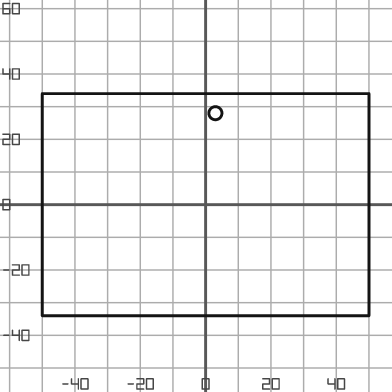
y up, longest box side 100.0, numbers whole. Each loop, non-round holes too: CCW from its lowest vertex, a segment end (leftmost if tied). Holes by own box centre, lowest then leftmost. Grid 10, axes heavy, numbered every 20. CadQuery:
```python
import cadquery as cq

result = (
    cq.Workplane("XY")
    .moveTo(-50.0, -34.0)
    .lineTo(50.0, -34.0)
    .lineTo(50.0, 34.0)
    .lineTo(-50.0, 34.0)
    .close()
    .moveTo(3.0, 28.0)
    .circle(2.0)
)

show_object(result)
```